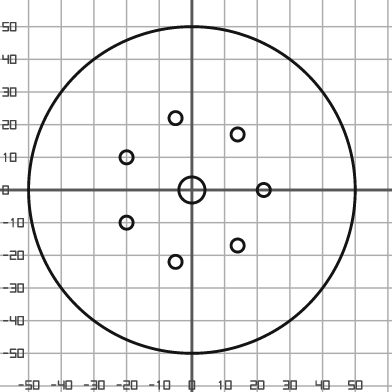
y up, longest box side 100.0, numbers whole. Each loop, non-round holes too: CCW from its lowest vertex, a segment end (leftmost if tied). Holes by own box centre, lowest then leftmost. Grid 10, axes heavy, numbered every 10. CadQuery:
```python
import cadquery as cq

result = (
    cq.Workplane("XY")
    .moveTo(0.0, 0.0)
    .circle(50.0)
    .moveTo(-5.0, -22.0)
    .circle(2.0)
    .moveTo(14.0, -17.0)
    .circle(2.0)
    .moveTo(-20.0, -10.0)
    .circle(2.0)
    .moveTo(0.0, 0.0)
    .circle(4.0)
    .moveTo(22.0, 0.0)
    .circle(2.0)
    .moveTo(-20.0, 10.0)
    .circle(2.0)
    .moveTo(14.0, 17.0)
    .circle(2.0)
    .moveTo(-5.0, 22.0)
    .circle(2.0)
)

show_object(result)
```